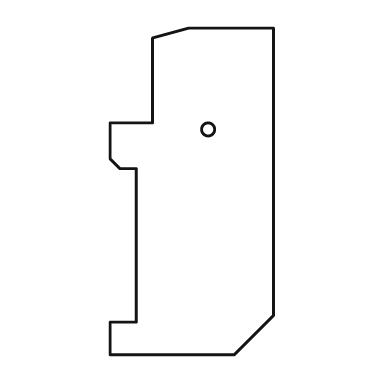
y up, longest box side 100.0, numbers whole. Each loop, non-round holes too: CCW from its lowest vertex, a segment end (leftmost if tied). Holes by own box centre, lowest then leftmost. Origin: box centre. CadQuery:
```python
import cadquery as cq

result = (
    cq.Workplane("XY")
    .moveTo(-25.0, -50.0)
    .lineTo(13.0, -50.0)
    .lineTo(25.0, -38.0)
    .lineTo(25.0, 50.0)
    .lineTo(-1.0, 50.0)
    .lineTo(-12.0, 47.0)
    .lineTo(-12.0, 21.0)
    .lineTo(-25.0, 21.0)
    .lineTo(-25.0, 10.0)
    .lineTo(-22.0, 7.0)
    .lineTo(-17.0, 7.0)
    .lineTo(-17.0, -40.0)
    .lineTo(-25.0, -40.0)
    .close()
    .moveTo(5.0, 19.0)
    .circle(2.0)
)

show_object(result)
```